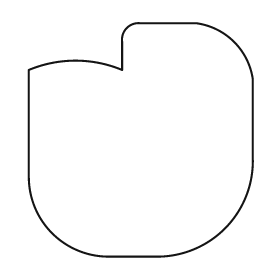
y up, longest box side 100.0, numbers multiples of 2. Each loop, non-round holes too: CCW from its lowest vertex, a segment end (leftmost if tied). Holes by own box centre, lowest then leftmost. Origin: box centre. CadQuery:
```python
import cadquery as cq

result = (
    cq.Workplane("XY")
    .moveTo(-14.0, -50.0)
    .lineTo(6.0, -50.0)
    .threePointArc((36.0, -38.0), (48.0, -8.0))
    .lineTo(48.0, 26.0)
    .threePointArc((40.0, 42.0), (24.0, 50.0))
    .lineTo(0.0, 50.0)
    .threePointArc((-6.0, 48.0), (-8.0, 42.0))
    .lineTo(-8.0, 30.0)
    .threePointArc((-28.0, 34.0), (-48.0, 30.0))
    .lineTo(-48.0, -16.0)
    .threePointArc((-38.0, -40.0), (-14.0, -50.0))
    .close()
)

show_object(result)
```